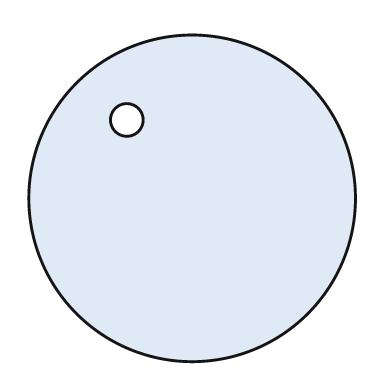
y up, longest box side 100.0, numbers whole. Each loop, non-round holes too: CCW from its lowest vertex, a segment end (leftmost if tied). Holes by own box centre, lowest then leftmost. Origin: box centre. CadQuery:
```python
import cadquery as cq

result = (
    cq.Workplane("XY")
    .moveTo(0.0, 0.0)
    .circle(50.0)
    .moveTo(-20.0, 24.0)
    .circle(5.0)
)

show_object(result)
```